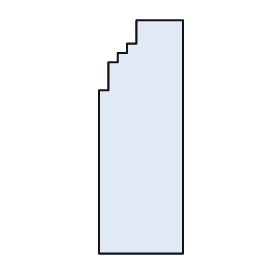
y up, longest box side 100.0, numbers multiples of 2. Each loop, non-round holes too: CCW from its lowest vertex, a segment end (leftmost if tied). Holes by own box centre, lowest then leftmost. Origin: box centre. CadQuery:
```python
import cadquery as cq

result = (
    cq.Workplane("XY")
    .moveTo(-18.0, -50.0)
    .lineTo(18.0, -50.0)
    .lineTo(18.0, 50.0)
    .lineTo(-2.0, 50.0)
    .lineTo(-2.0, 40.0)
    .lineTo(-6.0, 40.0)
    .lineTo(-6.0, 36.0)
    .lineTo(-10.0, 36.0)
    .lineTo(-10.0, 32.0)
    .lineTo(-14.0, 32.0)
    .lineTo(-14.0, 20.0)
    .lineTo(-18.0, 20.0)
    .close()
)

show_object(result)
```